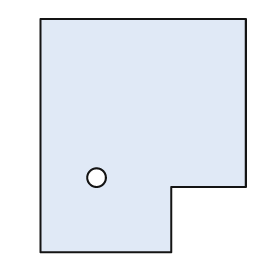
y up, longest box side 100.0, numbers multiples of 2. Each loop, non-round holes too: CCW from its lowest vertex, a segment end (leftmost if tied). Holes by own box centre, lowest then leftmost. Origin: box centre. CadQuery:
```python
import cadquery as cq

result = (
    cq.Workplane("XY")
    .moveTo(-44.0, -50.0)
    .lineTo(12.0, -50.0)
    .lineTo(12.0, -22.0)
    .lineTo(44.0, -22.0)
    .lineTo(44.0, 50.0)
    .lineTo(-44.0, 50.0)
    .close()
    .moveTo(-20.0, -18.0)
    .circle(4.0)
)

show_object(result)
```